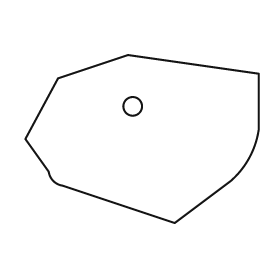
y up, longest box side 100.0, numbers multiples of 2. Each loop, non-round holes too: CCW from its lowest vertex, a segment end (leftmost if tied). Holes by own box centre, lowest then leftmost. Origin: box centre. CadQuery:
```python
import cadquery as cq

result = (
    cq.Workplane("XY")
    .moveTo(14.0, -36.0)
    .lineTo(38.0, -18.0)
    .threePointArc((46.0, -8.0), (50.0, 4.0))
    .lineTo(50.0, 28.0)
    .lineTo(-6.0, 36.0)
    .lineTo(-36.0, 26.0)
    .lineTo(-50.0, 0.0)
    .lineTo(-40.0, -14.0)
    .threePointArc((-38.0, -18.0), (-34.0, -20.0))
    .close()
    .moveTo(-4.0, 14.0)
    .circle(4.0)
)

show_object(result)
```